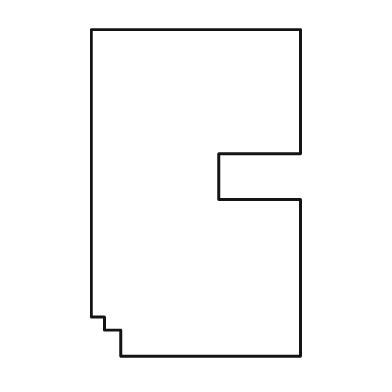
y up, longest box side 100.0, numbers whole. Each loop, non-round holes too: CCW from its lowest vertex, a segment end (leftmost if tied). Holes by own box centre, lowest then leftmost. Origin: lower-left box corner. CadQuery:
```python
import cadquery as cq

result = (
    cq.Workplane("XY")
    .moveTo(9.0, 0.0)
    .lineTo(64.0, 0.0)
    .lineTo(64.0, 48.0)
    .lineTo(39.0, 48.0)
    .lineTo(39.0, 62.0)
    .lineTo(64.0, 62.0)
    .lineTo(64.0, 100.0)
    .lineTo(0.0, 100.0)
    .lineTo(0.0, 12.0)
    .lineTo(4.0, 12.0)
    .lineTo(4.0, 8.0)
    .lineTo(9.0, 8.0)
    .close()
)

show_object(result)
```